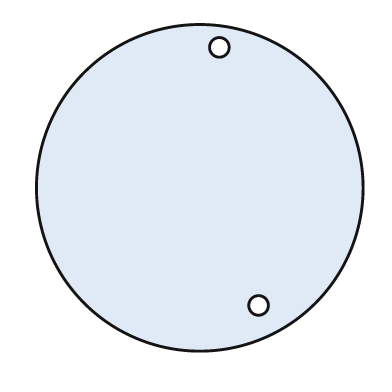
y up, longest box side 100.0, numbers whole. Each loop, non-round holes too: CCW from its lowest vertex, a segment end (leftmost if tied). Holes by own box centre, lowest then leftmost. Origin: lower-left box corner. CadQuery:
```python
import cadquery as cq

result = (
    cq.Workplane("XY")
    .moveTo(50.0, 50.0)
    .circle(50.0)
    .moveTo(68.0, 14.0)
    .circle(3.0)
    .moveTo(56.0, 93.0)
    .circle(3.0)
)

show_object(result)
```